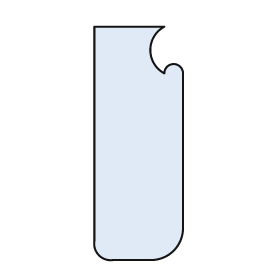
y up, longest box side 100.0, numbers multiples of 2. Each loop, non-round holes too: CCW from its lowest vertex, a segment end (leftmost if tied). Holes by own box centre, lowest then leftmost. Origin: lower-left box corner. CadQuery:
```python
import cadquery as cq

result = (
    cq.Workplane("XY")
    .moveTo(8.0, 0.0)
    .lineTo(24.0, 0.0)
    .threePointArc((34.0, 4.0), (38.0, 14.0))
    .lineTo(38.0, 80.0)
    .threePointArc((34.0, 84.0), (30.0, 80.0))
    .threePointArc((24.0, 90.0), (30.0, 100.0))
    .lineTo(0.0, 100.0)
    .lineTo(0.0, 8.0)
    .threePointArc((2.0, 2.0), (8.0, 0.0))
    .close()
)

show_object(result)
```